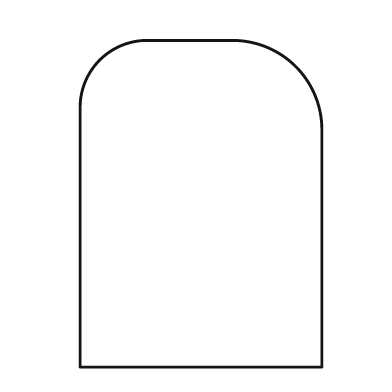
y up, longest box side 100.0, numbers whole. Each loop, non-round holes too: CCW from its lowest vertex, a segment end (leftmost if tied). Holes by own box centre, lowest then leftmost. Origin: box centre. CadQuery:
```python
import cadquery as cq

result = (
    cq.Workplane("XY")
    .moveTo(-37.0, -50.0)
    .lineTo(37.0, -50.0)
    .lineTo(37.0, 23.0)
    .threePointArc((29.0, 42.0), (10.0, 50.0))
    .lineTo(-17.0, 50.0)
    .threePointArc((-31.0, 44.0), (-37.0, 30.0))
    .close()
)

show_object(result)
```